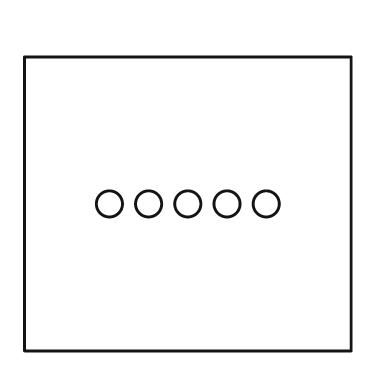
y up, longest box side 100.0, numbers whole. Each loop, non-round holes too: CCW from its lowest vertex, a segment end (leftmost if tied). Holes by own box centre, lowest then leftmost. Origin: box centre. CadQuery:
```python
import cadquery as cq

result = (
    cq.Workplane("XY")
    .moveTo(-50.0, -45.0)
    .lineTo(50.0, -45.0)
    .lineTo(50.0, 45.0)
    .lineTo(-50.0, 45.0)
    .close()
    .moveTo(-24.0, 0.0)
    .circle(4.0)
    .moveTo(-12.0, 0.0)
    .circle(4.0)
    .moveTo(0.0, 0.0)
    .circle(4.0)
    .moveTo(12.0, 0.0)
    .circle(4.0)
    .moveTo(24.0, 0.0)
    .circle(4.0)
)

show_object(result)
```